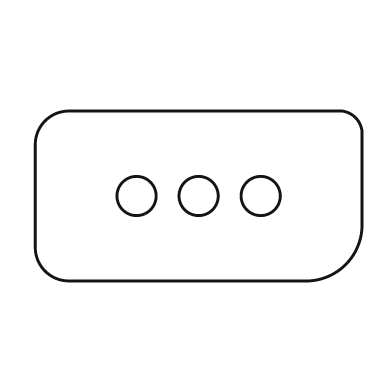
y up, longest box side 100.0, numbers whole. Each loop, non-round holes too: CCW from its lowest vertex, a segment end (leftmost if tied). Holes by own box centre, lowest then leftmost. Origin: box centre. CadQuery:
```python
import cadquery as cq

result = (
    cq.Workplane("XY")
    .moveTo(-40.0, -26.0)
    .lineTo(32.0, -26.0)
    .threePointArc((45.0, -21.0), (50.0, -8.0))
    .lineTo(50.0, 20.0)
    .threePointArc((48.0, 24.0), (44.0, 26.0))
    .lineTo(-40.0, 26.0)
    .threePointArc((-47.0, 23.0), (-50.0, 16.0))
    .lineTo(-50.0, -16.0)
    .threePointArc((-47.0, -23.0), (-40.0, -26.0))
    .close()
    .moveTo(-19.0, 0.0)
    .circle(6.0)
    .moveTo(0.0, 0.0)
    .circle(6.0)
    .moveTo(19.0, 0.0)
    .circle(6.0)
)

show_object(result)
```